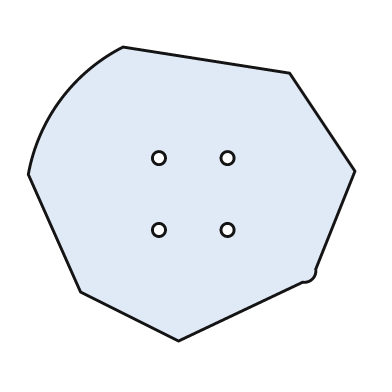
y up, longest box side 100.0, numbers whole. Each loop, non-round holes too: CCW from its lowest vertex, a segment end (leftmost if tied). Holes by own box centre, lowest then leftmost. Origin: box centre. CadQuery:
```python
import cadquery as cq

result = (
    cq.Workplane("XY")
    .moveTo(-4.0, -45.0)
    .lineTo(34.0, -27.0)
    .threePointArc((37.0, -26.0), (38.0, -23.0))
    .lineTo(50.0, 7.0)
    .lineTo(30.0, 37.0)
    .lineTo(-21.0, 45.0)
    .threePointArc((-40.0, 29.0), (-50.0, 6.0))
    .lineTo(-34.0, -30.0)
    .close()
    .moveTo(-10.0, -11.0)
    .circle(2.0)
    .moveTo(11.0, -11.0)
    .circle(2.0)
    .moveTo(-10.0, 11.0)
    .circle(2.0)
    .moveTo(11.0, 11.0)
    .circle(2.0)
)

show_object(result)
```